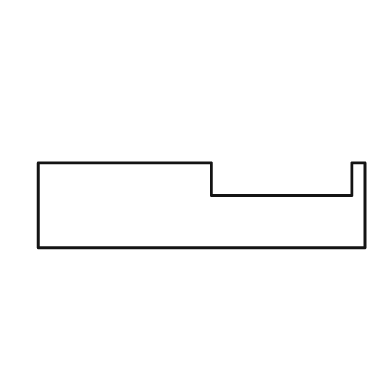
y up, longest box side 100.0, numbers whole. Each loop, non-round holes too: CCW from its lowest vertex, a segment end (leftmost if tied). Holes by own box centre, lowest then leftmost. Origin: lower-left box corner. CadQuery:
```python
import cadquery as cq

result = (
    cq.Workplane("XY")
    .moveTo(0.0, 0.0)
    .lineTo(100.0, 0.0)
    .lineTo(100.0, 26.0)
    .lineTo(96.0, 26.0)
    .lineTo(96.0, 16.0)
    .lineTo(53.0, 16.0)
    .lineTo(53.0, 26.0)
    .lineTo(0.0, 26.0)
    .close()
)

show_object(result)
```